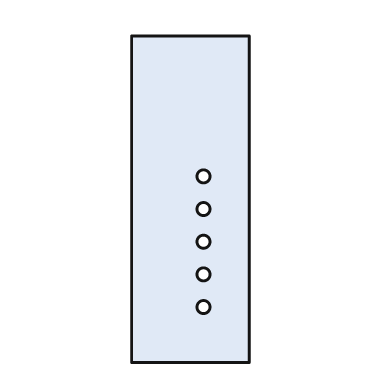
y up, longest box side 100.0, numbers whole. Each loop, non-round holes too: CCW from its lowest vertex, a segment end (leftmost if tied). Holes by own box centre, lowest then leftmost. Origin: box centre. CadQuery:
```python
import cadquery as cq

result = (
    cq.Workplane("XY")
    .moveTo(-18.0, -50.0)
    .lineTo(18.0, -50.0)
    .lineTo(18.0, 50.0)
    .lineTo(-18.0, 50.0)
    .close()
    .moveTo(4.0, -33.0)
    .circle(2.0)
    .moveTo(4.0, -23.0)
    .circle(2.0)
    .moveTo(4.0, -13.0)
    .circle(2.0)
    .moveTo(4.0, -3.0)
    .circle(2.0)
    .moveTo(4.0, 7.0)
    .circle(2.0)
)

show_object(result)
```